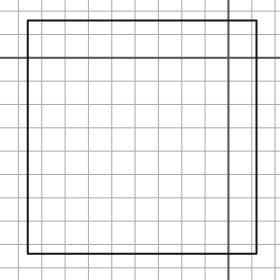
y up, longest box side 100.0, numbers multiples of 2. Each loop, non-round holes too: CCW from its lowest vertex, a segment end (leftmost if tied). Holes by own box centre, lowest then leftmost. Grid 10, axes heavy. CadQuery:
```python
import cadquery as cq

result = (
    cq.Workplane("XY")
    .moveTo(-86.0, -84.0)
    .lineTo(12.0, -84.0)
    .lineTo(12.0, 16.0)
    .lineTo(-86.0, 16.0)
    .close()
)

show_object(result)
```